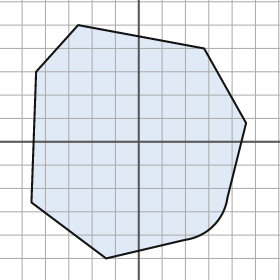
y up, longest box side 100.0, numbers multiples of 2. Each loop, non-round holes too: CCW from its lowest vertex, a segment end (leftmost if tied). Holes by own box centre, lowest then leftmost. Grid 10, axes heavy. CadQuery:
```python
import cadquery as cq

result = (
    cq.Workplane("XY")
    .moveTo(-14.0, -50.0)
    .lineTo(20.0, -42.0)
    .threePointArc((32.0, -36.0), (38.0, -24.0))
    .lineTo(46.0, 8.0)
    .lineTo(28.0, 40.0)
    .lineTo(-26.0, 50.0)
    .lineTo(-44.0, 30.0)
    .lineTo(-46.0, -26.0)
    .close()
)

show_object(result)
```